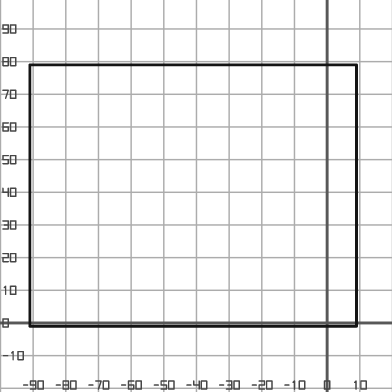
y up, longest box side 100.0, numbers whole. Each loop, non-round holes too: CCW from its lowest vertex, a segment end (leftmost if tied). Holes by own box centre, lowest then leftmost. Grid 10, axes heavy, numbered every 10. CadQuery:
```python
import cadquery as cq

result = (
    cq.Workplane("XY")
    .moveTo(-91.0, -1.0)
    .lineTo(9.0, -1.0)
    .lineTo(9.0, 79.0)
    .lineTo(-91.0, 79.0)
    .close()
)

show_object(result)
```